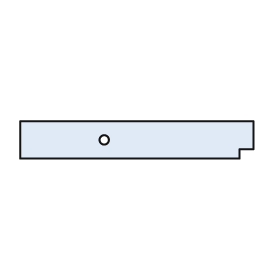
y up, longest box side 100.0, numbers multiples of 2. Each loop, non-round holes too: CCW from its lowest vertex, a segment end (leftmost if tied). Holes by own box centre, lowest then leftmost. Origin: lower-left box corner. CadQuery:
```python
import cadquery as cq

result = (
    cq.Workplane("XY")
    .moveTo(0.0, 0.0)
    .lineTo(94.0, 0.0)
    .lineTo(94.0, 4.0)
    .lineTo(100.0, 4.0)
    .lineTo(100.0, 16.0)
    .lineTo(0.0, 16.0)
    .close()
    .moveTo(36.0, 8.0)
    .circle(2.0)
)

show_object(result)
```